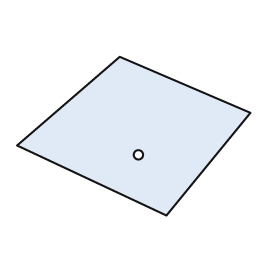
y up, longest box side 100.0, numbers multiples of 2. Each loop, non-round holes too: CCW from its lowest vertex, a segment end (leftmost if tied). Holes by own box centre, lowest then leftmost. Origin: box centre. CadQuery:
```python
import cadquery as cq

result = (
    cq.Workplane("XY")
    .moveTo(14.0, -34.0)
    .lineTo(50.0, 10.0)
    .lineTo(-6.0, 34.0)
    .lineTo(-50.0, -4.0)
    .close()
    .moveTo(2.0, -8.0)
    .circle(2.0)
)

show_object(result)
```